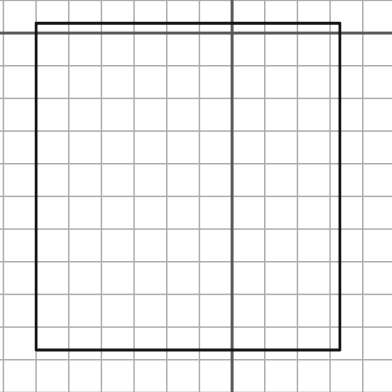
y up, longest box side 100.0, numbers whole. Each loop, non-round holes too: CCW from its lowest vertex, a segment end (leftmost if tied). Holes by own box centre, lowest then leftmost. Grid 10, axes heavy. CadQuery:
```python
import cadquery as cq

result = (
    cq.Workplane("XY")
    .moveTo(-60.0, -97.0)
    .lineTo(33.0, -97.0)
    .lineTo(33.0, 3.0)
    .lineTo(-60.0, 3.0)
    .close()
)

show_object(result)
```